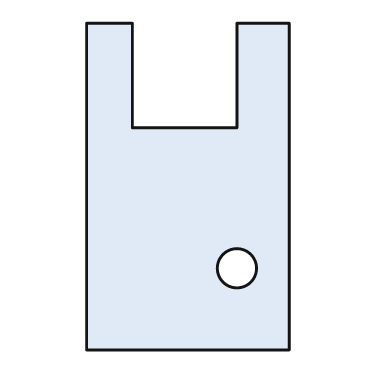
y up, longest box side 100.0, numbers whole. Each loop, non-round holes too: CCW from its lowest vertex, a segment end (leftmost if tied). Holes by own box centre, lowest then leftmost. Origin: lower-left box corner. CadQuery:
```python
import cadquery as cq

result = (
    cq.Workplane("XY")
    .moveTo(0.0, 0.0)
    .lineTo(62.0, 0.0)
    .lineTo(62.0, 100.0)
    .lineTo(46.0, 100.0)
    .lineTo(46.0, 68.0)
    .lineTo(14.0, 68.0)
    .lineTo(14.0, 100.0)
    .lineTo(0.0, 100.0)
    .close()
    .moveTo(46.0, 25.0)
    .circle(6.0)
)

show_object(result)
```